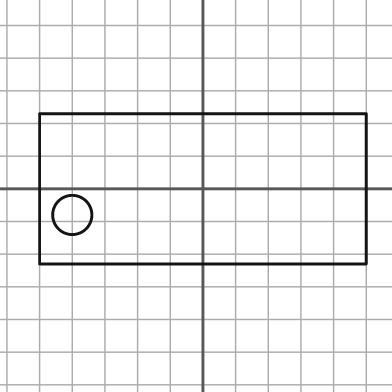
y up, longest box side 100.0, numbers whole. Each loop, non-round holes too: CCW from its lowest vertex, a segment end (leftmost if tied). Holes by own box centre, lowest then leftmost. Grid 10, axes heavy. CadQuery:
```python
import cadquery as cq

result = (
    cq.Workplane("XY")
    .moveTo(-50.0, -23.0)
    .lineTo(50.0, -23.0)
    .lineTo(50.0, 23.0)
    .lineTo(-50.0, 23.0)
    .close()
    .moveTo(-40.0, -8.0)
    .circle(6.0)
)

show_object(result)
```